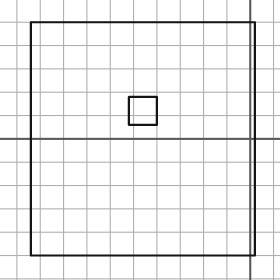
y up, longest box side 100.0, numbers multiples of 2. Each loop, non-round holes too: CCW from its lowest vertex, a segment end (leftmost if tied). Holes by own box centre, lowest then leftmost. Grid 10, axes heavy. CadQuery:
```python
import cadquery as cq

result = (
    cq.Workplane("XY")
    .moveTo(-94.0, -50.0)
    .lineTo(2.0, -50.0)
    .lineTo(2.0, 50.0)
    .lineTo(-94.0, 50.0)
    .close()
    .moveTo(-52.0, 6.0)
    .lineTo(-40.0, 6.0)
    .lineTo(-40.0, 18.0)
    .lineTo(-52.0, 18.0)
    .close()
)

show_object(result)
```